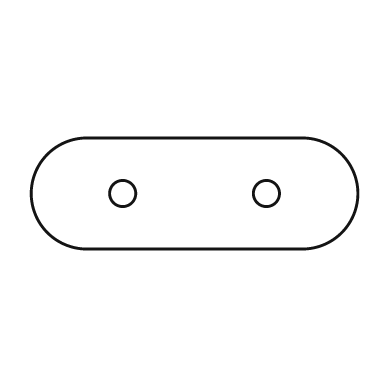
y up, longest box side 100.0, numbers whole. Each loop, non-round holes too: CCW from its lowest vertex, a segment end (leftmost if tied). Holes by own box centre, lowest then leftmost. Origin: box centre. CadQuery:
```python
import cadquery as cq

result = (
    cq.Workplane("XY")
    .moveTo(-33.0, -17.0)
    .lineTo(33.0, -17.0)
    .threePointArc((50.0, 0.0), (33.0, 17.0))
    .lineTo(-33.0, 17.0)
    .threePointArc((-50.0, 0.0), (-33.0, -17.0))
    .close()
    .moveTo(-22.0, 0.0)
    .circle(4.0)
    .moveTo(22.0, 0.0)
    .circle(4.0)
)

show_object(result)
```